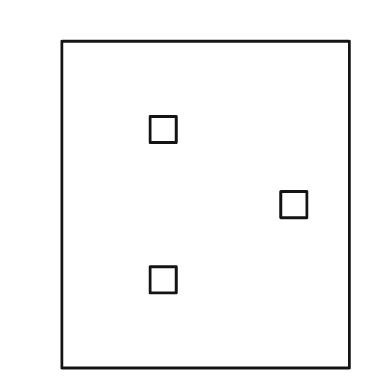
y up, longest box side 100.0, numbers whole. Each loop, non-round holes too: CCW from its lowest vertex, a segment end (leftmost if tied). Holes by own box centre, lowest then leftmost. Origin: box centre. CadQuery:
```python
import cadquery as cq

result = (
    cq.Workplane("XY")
    .moveTo(-44.0, -50.0)
    .lineTo(44.0, -50.0)
    .lineTo(44.0, 50.0)
    .lineTo(-44.0, 50.0)
    .close()
    .moveTo(-17.0, -27.0)
    .lineTo(-9.0, -27.0)
    .lineTo(-9.0, -19.0)
    .lineTo(-17.0, -19.0)
    .close()
    .moveTo(23.0, -4.0)
    .lineTo(31.0, -4.0)
    .lineTo(31.0, 4.0)
    .lineTo(23.0, 4.0)
    .close()
    .moveTo(-17.0, 19.0)
    .lineTo(-9.0, 19.0)
    .lineTo(-9.0, 27.0)
    .lineTo(-17.0, 27.0)
    .close()
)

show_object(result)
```